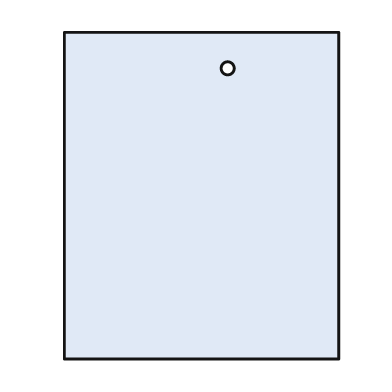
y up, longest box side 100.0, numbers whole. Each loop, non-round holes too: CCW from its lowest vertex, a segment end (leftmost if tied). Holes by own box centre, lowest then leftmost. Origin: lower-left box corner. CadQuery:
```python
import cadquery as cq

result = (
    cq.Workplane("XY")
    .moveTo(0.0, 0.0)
    .lineTo(84.0, 0.0)
    .lineTo(84.0, 100.0)
    .lineTo(0.0, 100.0)
    .close()
    .moveTo(50.0, 89.0)
    .circle(2.0)
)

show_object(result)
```